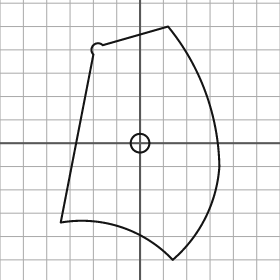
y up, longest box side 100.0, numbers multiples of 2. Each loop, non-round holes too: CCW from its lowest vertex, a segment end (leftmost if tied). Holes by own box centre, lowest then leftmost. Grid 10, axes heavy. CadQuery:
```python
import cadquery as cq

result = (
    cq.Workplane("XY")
    .moveTo(14.0, -50.0)
    .threePointArc((28.0, -32.0), (34.0, -10.0))
    .threePointArc((28.0, 22.0), (12.0, 50.0))
    .lineTo(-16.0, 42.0)
    .threePointArc((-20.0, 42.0), (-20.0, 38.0))
    .lineTo(-34.0, -34.0)
    .threePointArc((-8.0, -36.0), (14.0, -50.0))
    .close()
    .moveTo(0.0, 0.0)
    .circle(4.0)
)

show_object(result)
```